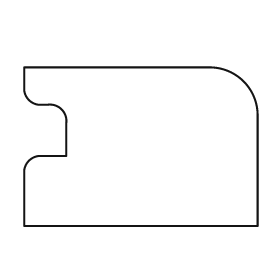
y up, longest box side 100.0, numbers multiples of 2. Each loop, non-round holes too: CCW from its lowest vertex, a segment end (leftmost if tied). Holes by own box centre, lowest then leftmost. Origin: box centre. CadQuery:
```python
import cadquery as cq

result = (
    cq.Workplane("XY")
    .moveTo(-50.0, -34.0)
    .lineTo(50.0, -34.0)
    .lineTo(50.0, 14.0)
    .threePointArc((44.0, 28.0), (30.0, 34.0))
    .lineTo(-50.0, 34.0)
    .lineTo(-50.0, 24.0)
    .threePointArc((-48.0, 20.0), (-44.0, 18.0))
    .lineTo(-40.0, 18.0)
    .threePointArc((-34.0, 16.0), (-32.0, 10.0))
    .lineTo(-32.0, -4.0)
    .lineTo(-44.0, -4.0)
    .threePointArc((-48.0, -6.0), (-50.0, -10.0))
    .close()
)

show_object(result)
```